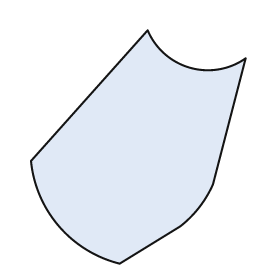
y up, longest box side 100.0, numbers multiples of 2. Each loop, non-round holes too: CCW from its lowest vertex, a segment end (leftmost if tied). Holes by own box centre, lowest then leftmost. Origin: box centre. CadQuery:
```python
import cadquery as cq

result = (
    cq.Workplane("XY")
    .moveTo(-8.0, -50.0)
    .lineTo(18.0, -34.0)
    .threePointArc((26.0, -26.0), (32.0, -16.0))
    .lineTo(46.0, 38.0)
    .threePointArc((22.0, 34.0), (4.0, 50.0))
    .lineTo(-46.0, -6.0)
    .threePointArc((-34.0, -34.0), (-8.0, -50.0))
    .close()
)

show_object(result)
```